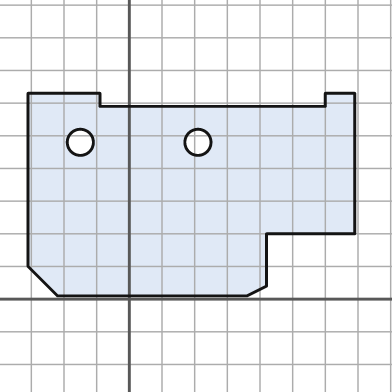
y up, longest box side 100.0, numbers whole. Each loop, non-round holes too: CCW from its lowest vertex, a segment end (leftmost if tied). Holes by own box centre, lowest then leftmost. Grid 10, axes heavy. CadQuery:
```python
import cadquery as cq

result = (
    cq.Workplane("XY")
    .moveTo(-22.0, 1.0)
    .lineTo(36.0, 1.0)
    .lineTo(42.0, 4.0)
    .lineTo(42.0, 20.0)
    .lineTo(69.0, 20.0)
    .lineTo(69.0, 63.0)
    .lineTo(60.0, 63.0)
    .lineTo(60.0, 59.0)
    .lineTo(-9.0, 59.0)
    .lineTo(-9.0, 63.0)
    .lineTo(-31.0, 63.0)
    .lineTo(-31.0, 10.0)
    .close()
    .moveTo(-15.0, 48.0)
    .circle(4.0)
    .moveTo(21.0, 48.0)
    .circle(4.0)
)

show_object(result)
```